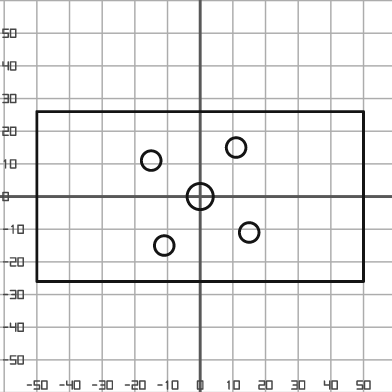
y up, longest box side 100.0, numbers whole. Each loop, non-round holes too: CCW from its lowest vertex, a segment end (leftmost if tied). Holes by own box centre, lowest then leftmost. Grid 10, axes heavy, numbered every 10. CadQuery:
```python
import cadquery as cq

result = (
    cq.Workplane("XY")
    .moveTo(-50.0, -26.0)
    .lineTo(50.0, -26.0)
    .lineTo(50.0, 26.0)
    .lineTo(-50.0, 26.0)
    .close()
    .moveTo(-11.0, -15.0)
    .circle(3.0)
    .moveTo(15.0, -11.0)
    .circle(3.0)
    .moveTo(0.0, 0.0)
    .circle(4.0)
    .moveTo(-15.0, 11.0)
    .circle(3.0)
    .moveTo(11.0, 15.0)
    .circle(3.0)
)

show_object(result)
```